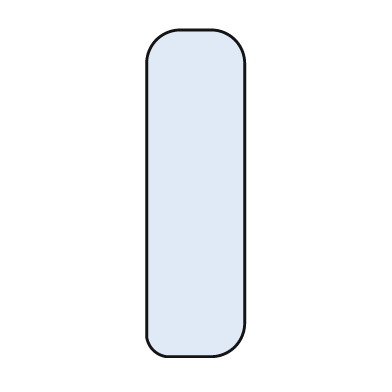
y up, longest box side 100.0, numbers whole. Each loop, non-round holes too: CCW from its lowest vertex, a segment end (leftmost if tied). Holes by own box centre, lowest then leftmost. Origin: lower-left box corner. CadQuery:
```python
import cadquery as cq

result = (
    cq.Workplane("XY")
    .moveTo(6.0, 0.0)
    .lineTo(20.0, 0.0)
    .threePointArc((27.0, 3.0), (30.0, 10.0))
    .lineTo(30.0, 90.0)
    .threePointArc((27.0, 97.0), (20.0, 100.0))
    .lineTo(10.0, 100.0)
    .threePointArc((3.0, 97.0), (0.0, 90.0))
    .lineTo(0.0, 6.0)
    .threePointArc((2.0, 2.0), (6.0, 0.0))
    .close()
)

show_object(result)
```